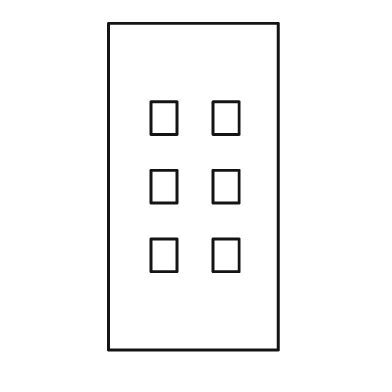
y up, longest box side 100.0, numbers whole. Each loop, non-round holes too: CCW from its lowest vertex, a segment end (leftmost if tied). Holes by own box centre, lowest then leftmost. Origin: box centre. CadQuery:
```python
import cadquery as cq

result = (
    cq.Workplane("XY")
    .moveTo(-26.0, -50.0)
    .lineTo(26.0, -50.0)
    .lineTo(26.0, 50.0)
    .lineTo(-26.0, 50.0)
    .close()
    .moveTo(-13.0, -26.0)
    .lineTo(-5.0, -26.0)
    .lineTo(-5.0, -16.0)
    .lineTo(-13.0, -16.0)
    .close()
    .moveTo(6.0, -26.0)
    .lineTo(14.0, -26.0)
    .lineTo(14.0, -16.0)
    .lineTo(6.0, -16.0)
    .close()
    .moveTo(-13.0, -5.0)
    .lineTo(-5.0, -5.0)
    .lineTo(-5.0, 5.0)
    .lineTo(-13.0, 5.0)
    .close()
    .moveTo(6.0, -5.0)
    .lineTo(14.0, -5.0)
    .lineTo(14.0, 5.0)
    .lineTo(6.0, 5.0)
    .close()
    .moveTo(-13.0, 16.0)
    .lineTo(-5.0, 16.0)
    .lineTo(-5.0, 26.0)
    .lineTo(-13.0, 26.0)
    .close()
    .moveTo(6.0, 16.0)
    .lineTo(14.0, 16.0)
    .lineTo(14.0, 26.0)
    .lineTo(6.0, 26.0)
    .close()
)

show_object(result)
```